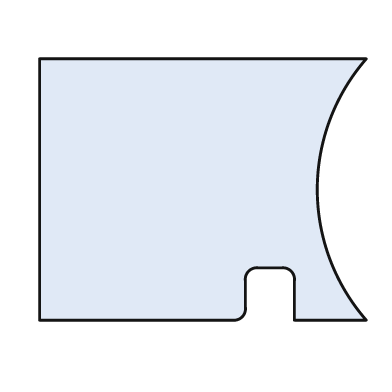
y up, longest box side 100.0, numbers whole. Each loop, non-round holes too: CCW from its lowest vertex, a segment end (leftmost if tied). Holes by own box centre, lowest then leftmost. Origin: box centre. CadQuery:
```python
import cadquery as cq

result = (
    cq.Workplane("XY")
    .moveTo(-50.0, -40.0)
    .lineTo(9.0, -40.0)
    .threePointArc((12.0, -39.0), (13.0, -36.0))
    .lineTo(13.0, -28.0)
    .threePointArc((14.0, -25.0), (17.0, -24.0))
    .lineTo(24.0, -24.0)
    .threePointArc((27.0, -25.0), (28.0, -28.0))
    .lineTo(28.0, -40.0)
    .lineTo(50.0, -40.0)
    .threePointArc((35.0, 0.0), (50.0, 40.0))
    .lineTo(-50.0, 40.0)
    .close()
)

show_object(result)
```